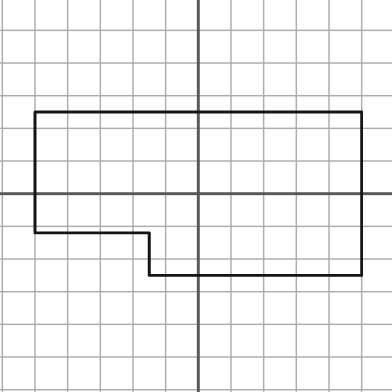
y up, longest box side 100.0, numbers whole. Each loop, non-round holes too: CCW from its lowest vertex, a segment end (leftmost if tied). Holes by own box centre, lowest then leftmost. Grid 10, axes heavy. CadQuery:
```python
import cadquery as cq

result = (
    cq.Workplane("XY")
    .moveTo(-15.0, -25.0)
    .lineTo(50.0, -25.0)
    .lineTo(50.0, 25.0)
    .lineTo(-50.0, 25.0)
    .lineTo(-50.0, -12.0)
    .lineTo(-15.0, -12.0)
    .close()
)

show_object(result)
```